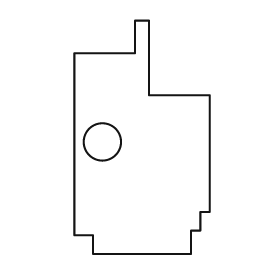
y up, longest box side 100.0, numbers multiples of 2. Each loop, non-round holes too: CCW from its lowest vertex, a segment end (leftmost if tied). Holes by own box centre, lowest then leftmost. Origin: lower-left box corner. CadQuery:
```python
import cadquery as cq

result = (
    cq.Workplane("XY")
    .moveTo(8.0, 0.0)
    .lineTo(50.0, 0.0)
    .lineTo(50.0, 10.0)
    .lineTo(54.0, 10.0)
    .lineTo(54.0, 18.0)
    .lineTo(58.0, 18.0)
    .lineTo(58.0, 68.0)
    .lineTo(32.0, 68.0)
    .lineTo(32.0, 100.0)
    .lineTo(26.0, 100.0)
    .lineTo(26.0, 86.0)
    .lineTo(0.0, 86.0)
    .lineTo(0.0, 8.0)
    .lineTo(8.0, 8.0)
    .close()
    .moveTo(12.0, 48.0)
    .circle(8.0)
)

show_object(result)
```